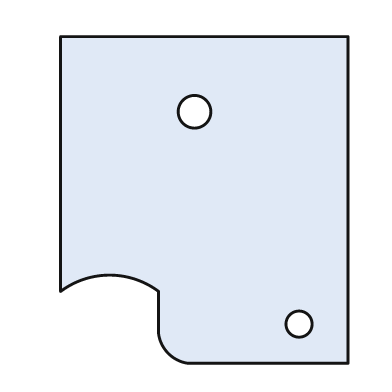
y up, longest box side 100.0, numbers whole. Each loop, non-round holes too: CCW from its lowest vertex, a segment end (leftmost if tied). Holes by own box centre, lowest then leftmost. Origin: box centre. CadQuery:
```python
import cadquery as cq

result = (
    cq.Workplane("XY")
    .moveTo(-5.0, -50.0)
    .lineTo(44.0, -50.0)
    .lineTo(44.0, 50.0)
    .lineTo(-44.0, 50.0)
    .lineTo(-44.0, -28.0)
    .threePointArc((-29.0, -23.0), (-14.0, -28.0))
    .lineTo(-14.0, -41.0)
    .threePointArc((-11.0, -47.0), (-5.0, -50.0))
    .close()
    .moveTo(29.0, -38.0)
    .circle(4.0)
    .moveTo(-3.0, 27.0)
    .circle(5.0)
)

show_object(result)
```